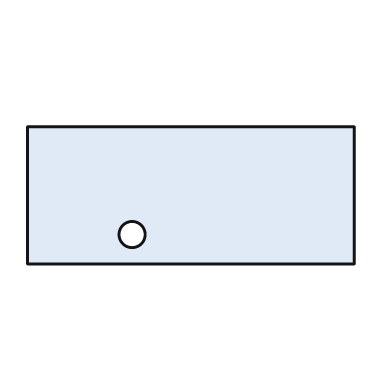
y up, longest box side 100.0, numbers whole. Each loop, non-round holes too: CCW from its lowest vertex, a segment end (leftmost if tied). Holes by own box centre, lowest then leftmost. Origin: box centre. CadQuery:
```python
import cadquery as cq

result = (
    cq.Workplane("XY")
    .moveTo(-50.0, -21.0)
    .lineTo(50.0, -21.0)
    .lineTo(50.0, 21.0)
    .lineTo(-50.0, 21.0)
    .close()
    .moveTo(-18.0, -12.0)
    .circle(4.0)
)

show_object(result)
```